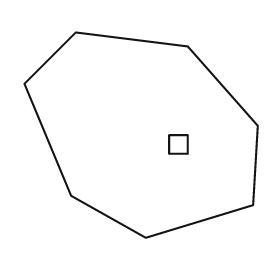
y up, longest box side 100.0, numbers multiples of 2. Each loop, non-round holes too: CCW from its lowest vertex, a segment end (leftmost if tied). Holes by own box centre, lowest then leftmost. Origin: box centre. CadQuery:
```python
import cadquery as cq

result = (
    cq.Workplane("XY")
    .moveTo(2.0, -44.0)
    .lineTo(48.0, -30.0)
    .lineTo(50.0, 4.0)
    .lineTo(20.0, 38.0)
    .lineTo(-28.0, 44.0)
    .lineTo(-50.0, 22.0)
    .lineTo(-30.0, -26.0)
    .close()
    .moveTo(12.0, -8.0)
    .lineTo(20.0, -8.0)
    .lineTo(20.0, 0.0)
    .lineTo(12.0, 0.0)
    .close()
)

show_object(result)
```